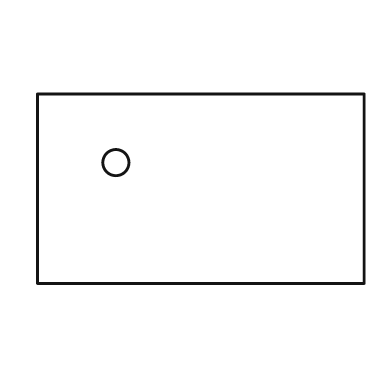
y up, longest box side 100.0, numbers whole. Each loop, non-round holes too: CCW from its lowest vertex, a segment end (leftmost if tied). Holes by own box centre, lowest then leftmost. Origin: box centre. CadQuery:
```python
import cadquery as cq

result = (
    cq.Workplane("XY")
    .moveTo(-50.0, -29.0)
    .lineTo(50.0, -29.0)
    .lineTo(50.0, 29.0)
    .lineTo(-50.0, 29.0)
    .close()
    .moveTo(-26.0, 8.0)
    .circle(4.0)
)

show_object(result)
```